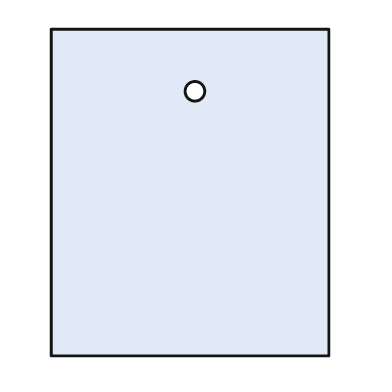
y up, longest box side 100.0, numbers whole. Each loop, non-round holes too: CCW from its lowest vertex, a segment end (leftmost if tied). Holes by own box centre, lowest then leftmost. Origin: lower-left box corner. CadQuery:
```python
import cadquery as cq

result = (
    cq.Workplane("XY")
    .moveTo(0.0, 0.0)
    .lineTo(85.0, 0.0)
    .lineTo(85.0, 100.0)
    .lineTo(0.0, 100.0)
    .close()
    .moveTo(44.0, 81.0)
    .circle(3.0)
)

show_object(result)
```